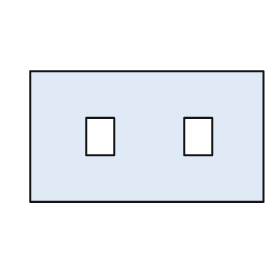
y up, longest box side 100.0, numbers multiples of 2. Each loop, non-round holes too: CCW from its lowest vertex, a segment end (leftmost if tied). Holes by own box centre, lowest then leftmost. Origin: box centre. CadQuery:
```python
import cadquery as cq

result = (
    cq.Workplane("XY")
    .moveTo(-50.0, -28.0)
    .lineTo(50.0, -28.0)
    .lineTo(50.0, 28.0)
    .lineTo(-50.0, 28.0)
    .close()
    .moveTo(-26.0, -8.0)
    .lineTo(-14.0, -8.0)
    .lineTo(-14.0, 8.0)
    .lineTo(-26.0, 8.0)
    .close()
    .moveTo(16.0, -8.0)
    .lineTo(28.0, -8.0)
    .lineTo(28.0, 8.0)
    .lineTo(16.0, 8.0)
    .close()
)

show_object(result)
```